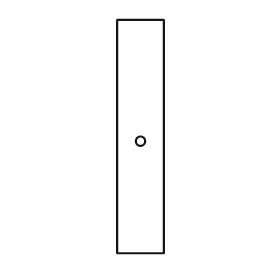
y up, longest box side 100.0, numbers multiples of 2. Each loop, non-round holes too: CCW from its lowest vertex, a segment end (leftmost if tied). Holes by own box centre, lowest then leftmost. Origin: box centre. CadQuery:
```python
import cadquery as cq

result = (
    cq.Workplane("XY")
    .moveTo(-10.0, -50.0)
    .lineTo(10.0, -50.0)
    .lineTo(10.0, 50.0)
    .lineTo(-10.0, 50.0)
    .close()
    .moveTo(0.0, -2.0)
    .circle(2.0)
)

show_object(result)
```